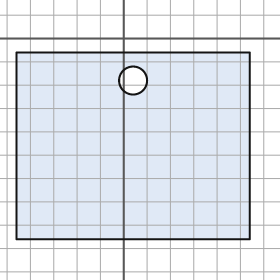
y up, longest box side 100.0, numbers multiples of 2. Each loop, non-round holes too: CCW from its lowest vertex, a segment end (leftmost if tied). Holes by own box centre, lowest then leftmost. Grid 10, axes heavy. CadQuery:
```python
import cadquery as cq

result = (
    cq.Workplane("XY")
    .moveTo(-46.0, -86.0)
    .lineTo(54.0, -86.0)
    .lineTo(54.0, -6.0)
    .lineTo(-46.0, -6.0)
    .close()
    .moveTo(4.0, -18.0)
    .circle(6.0)
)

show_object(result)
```